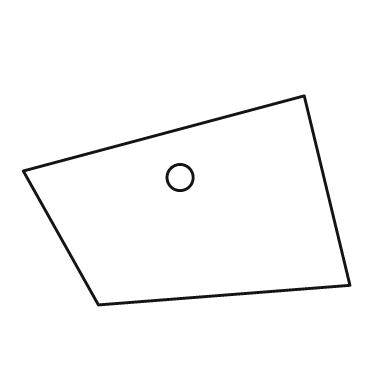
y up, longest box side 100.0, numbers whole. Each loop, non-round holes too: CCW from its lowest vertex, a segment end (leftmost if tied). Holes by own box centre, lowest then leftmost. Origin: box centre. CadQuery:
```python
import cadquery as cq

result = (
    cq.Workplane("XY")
    .moveTo(-27.0, -32.0)
    .lineTo(50.0, -26.0)
    .lineTo(36.0, 32.0)
    .lineTo(-50.0, 9.0)
    .close()
    .moveTo(-2.0, 7.0)
    .circle(4.0)
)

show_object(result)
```